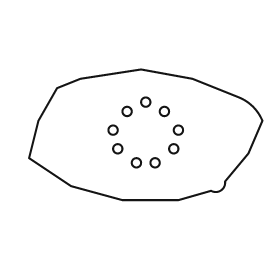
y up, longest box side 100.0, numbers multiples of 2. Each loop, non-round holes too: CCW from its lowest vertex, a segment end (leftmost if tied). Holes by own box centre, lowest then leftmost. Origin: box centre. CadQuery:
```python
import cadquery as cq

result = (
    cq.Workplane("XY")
    .moveTo(-10.0, -28.0)
    .lineTo(14.0, -28.0)
    .lineTo(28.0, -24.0)
    .threePointArc((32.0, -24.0), (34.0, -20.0))
    .lineTo(44.0, -8.0)
    .lineTo(50.0, 6.0)
    .threePointArc((46.0, 12.0), (40.0, 16.0))
    .lineTo(20.0, 24.0)
    .lineTo(-2.0, 28.0)
    .lineTo(-28.0, 24.0)
    .lineTo(-38.0, 20.0)
    .lineTo(-46.0, 6.0)
    .lineTo(-50.0, -10.0)
    .lineTo(-32.0, -22.0)
    .close()
    .moveTo(-4.0, -12.0)
    .circle(2.0)
    .moveTo(4.0, -12.0)
    .circle(2.0)
    .moveTo(-12.0, -6.0)
    .circle(2.0)
    .moveTo(12.0, -6.0)
    .circle(2.0)
    .moveTo(-14.0, 2.0)
    .circle(2.0)
    .moveTo(14.0, 2.0)
    .circle(2.0)
    .moveTo(-8.0, 10.0)
    .circle(2.0)
    .moveTo(8.0, 10.0)
    .circle(2.0)
    .moveTo(0.0, 14.0)
    .circle(2.0)
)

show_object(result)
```